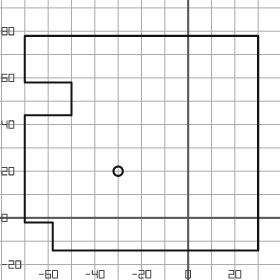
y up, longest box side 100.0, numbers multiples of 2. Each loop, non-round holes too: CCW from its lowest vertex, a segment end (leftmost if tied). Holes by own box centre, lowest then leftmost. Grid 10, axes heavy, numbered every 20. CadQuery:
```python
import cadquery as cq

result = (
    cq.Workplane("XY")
    .moveTo(-58.0, -14.0)
    .lineTo(30.0, -14.0)
    .lineTo(30.0, 78.0)
    .lineTo(-70.0, 78.0)
    .lineTo(-70.0, 58.0)
    .lineTo(-50.0, 58.0)
    .lineTo(-50.0, 44.0)
    .lineTo(-70.0, 44.0)
    .lineTo(-70.0, -2.0)
    .lineTo(-58.0, -2.0)
    .close()
    .moveTo(-30.0, 20.0)
    .circle(2.0)
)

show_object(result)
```